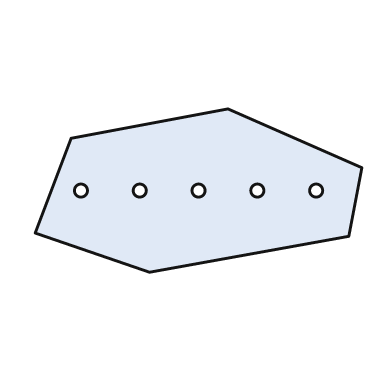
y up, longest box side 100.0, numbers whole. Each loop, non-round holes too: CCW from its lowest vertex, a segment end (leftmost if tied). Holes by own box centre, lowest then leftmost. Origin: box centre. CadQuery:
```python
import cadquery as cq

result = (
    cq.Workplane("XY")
    .moveTo(-15.0, -25.0)
    .lineTo(46.0, -14.0)
    .lineTo(50.0, 7.0)
    .lineTo(9.0, 25.0)
    .lineTo(-39.0, 16.0)
    .lineTo(-50.0, -13.0)
    .close()
    .moveTo(-36.0, 0.0)
    .circle(2.0)
    .moveTo(-18.0, 0.0)
    .circle(2.0)
    .moveTo(0.0, 0.0)
    .circle(2.0)
    .moveTo(18.0, 0.0)
    .circle(2.0)
    .moveTo(36.0, 0.0)
    .circle(2.0)
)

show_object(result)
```